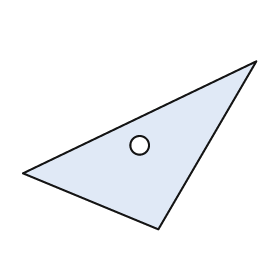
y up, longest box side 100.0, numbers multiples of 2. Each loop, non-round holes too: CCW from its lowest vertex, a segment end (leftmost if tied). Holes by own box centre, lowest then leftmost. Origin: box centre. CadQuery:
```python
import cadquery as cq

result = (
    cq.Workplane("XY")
    .moveTo(8.0, -36.0)
    .lineTo(50.0, 36.0)
    .lineTo(-50.0, -12.0)
    .close()
    .moveTo(0.0, 0.0)
    .circle(4.0)
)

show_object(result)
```